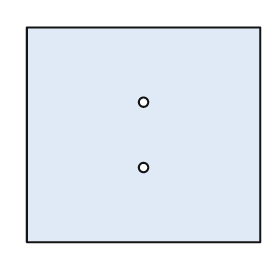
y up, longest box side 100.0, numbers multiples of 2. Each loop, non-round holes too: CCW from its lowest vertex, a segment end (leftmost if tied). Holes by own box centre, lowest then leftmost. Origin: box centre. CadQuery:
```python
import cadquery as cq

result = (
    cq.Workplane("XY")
    .moveTo(-50.0, -46.0)
    .lineTo(50.0, -46.0)
    .lineTo(50.0, 46.0)
    .lineTo(-50.0, 46.0)
    .close()
    .moveTo(0.0, -14.0)
    .circle(2.0)
    .moveTo(0.0, 14.0)
    .circle(2.0)
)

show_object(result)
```